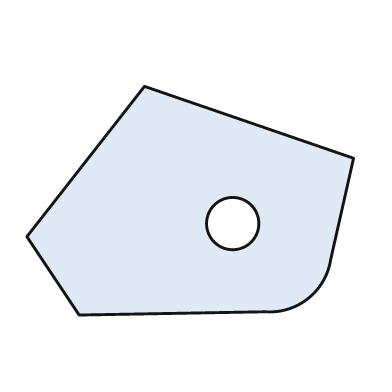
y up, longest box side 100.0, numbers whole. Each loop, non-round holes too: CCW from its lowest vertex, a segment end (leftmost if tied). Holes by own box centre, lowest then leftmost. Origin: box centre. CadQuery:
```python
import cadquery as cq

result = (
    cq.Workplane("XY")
    .moveTo(-34.0, -35.0)
    .lineTo(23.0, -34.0)
    .threePointArc((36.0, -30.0), (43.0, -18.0))
    .lineTo(50.0, 13.0)
    .lineTo(-14.0, 35.0)
    .lineTo(-50.0, -11.0)
    .close()
    .moveTo(13.0, -7.0)
    .circle(8.0)
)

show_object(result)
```